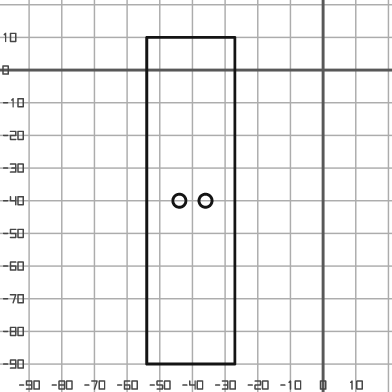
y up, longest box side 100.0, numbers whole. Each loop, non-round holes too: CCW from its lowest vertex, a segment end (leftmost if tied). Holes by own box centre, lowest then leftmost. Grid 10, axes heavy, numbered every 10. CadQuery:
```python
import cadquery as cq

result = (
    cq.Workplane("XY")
    .moveTo(-54.0, -90.0)
    .lineTo(-27.0, -90.0)
    .lineTo(-27.0, 10.0)
    .lineTo(-54.0, 10.0)
    .close()
    .moveTo(-44.0, -40.0)
    .circle(2.0)
    .moveTo(-36.0, -40.0)
    .circle(2.0)
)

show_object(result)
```